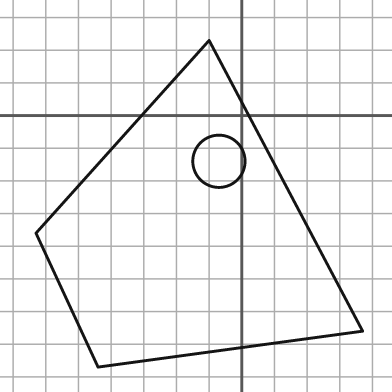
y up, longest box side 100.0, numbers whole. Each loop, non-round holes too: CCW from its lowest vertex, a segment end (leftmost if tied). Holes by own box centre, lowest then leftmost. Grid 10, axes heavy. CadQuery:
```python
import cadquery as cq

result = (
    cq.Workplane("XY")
    .moveTo(-44.0, -77.0)
    .lineTo(37.0, -66.0)
    .lineTo(-10.0, 23.0)
    .lineTo(-63.0, -36.0)
    .close()
    .moveTo(-7.0, -14.0)
    .circle(8.0)
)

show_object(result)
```